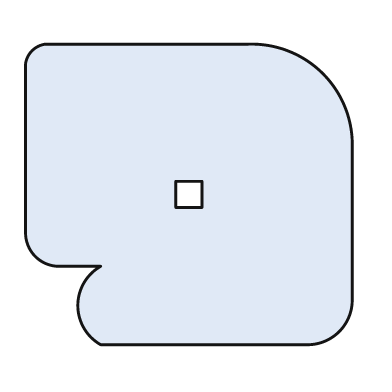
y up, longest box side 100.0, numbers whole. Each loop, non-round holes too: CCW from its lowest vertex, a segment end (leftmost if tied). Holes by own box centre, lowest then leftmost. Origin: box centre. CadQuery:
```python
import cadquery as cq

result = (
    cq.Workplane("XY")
    .moveTo(-27.0, -46.0)
    .lineTo(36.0, -46.0)
    .threePointArc((46.0, -42.0), (50.0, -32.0))
    .lineTo(50.0, 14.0)
    .threePointArc((41.0, 37.0), (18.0, 46.0))
    .lineTo(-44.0, 46.0)
    .threePointArc((-48.0, 44.0), (-50.0, 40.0))
    .lineTo(-50.0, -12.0)
    .threePointArc((-47.0, -19.0), (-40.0, -22.0))
    .lineTo(-27.0, -22.0)
    .threePointArc((-34.0, -34.0), (-27.0, -46.0))
    .close()
    .moveTo(-4.0, -4.0)
    .lineTo(4.0, -4.0)
    .lineTo(4.0, 4.0)
    .lineTo(-4.0, 4.0)
    .close()
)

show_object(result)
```